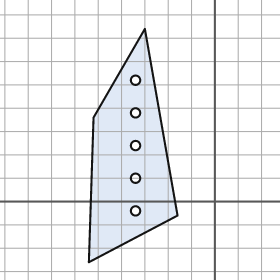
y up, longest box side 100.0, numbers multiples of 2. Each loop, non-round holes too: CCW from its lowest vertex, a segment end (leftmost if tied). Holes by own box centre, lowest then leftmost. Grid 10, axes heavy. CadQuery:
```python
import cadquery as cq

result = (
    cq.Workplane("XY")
    .moveTo(-54.0, -26.0)
    .lineTo(-16.0, -6.0)
    .lineTo(-30.0, 74.0)
    .lineTo(-52.0, 36.0)
    .close()
    .moveTo(-34.0, -4.0)
    .circle(2.0)
    .moveTo(-34.0, 10.0)
    .circle(2.0)
    .moveTo(-34.0, 24.0)
    .circle(2.0)
    .moveTo(-34.0, 38.0)
    .circle(2.0)
    .moveTo(-34.0, 52.0)
    .circle(2.0)
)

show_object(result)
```